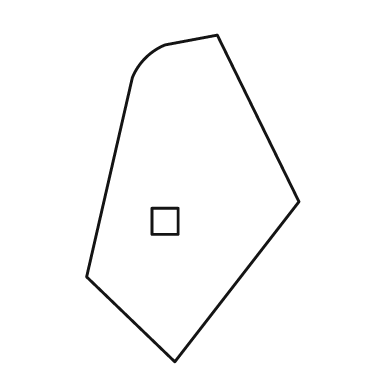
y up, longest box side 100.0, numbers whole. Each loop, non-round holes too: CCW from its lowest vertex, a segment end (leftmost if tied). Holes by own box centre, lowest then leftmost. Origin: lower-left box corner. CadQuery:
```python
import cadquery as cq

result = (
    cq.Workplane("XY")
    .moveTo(27.0, 0.0)
    .lineTo(65.0, 49.0)
    .lineTo(40.0, 100.0)
    .lineTo(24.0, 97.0)
    .threePointArc((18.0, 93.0), (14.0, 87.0))
    .lineTo(0.0, 26.0)
    .close()
    .moveTo(20.0, 39.0)
    .lineTo(28.0, 39.0)
    .lineTo(28.0, 47.0)
    .lineTo(20.0, 47.0)
    .close()
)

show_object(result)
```